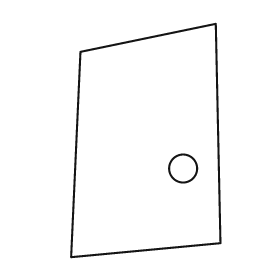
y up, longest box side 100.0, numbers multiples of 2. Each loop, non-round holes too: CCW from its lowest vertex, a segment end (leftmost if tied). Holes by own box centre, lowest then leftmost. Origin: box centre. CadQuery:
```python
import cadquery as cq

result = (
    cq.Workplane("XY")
    .moveTo(-32.0, -50.0)
    .lineTo(32.0, -44.0)
    .lineTo(30.0, 50.0)
    .lineTo(-28.0, 38.0)
    .close()
    .moveTo(16.0, -12.0)
    .circle(6.0)
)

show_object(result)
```